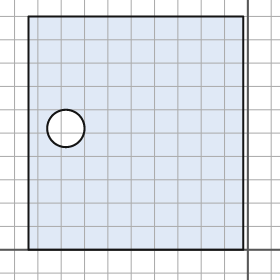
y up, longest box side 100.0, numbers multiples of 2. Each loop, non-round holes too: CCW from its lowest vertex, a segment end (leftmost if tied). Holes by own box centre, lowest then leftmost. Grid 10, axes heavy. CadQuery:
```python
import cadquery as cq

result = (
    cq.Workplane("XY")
    .moveTo(-94.0, 0.0)
    .lineTo(-2.0, 0.0)
    .lineTo(-2.0, 100.0)
    .lineTo(-94.0, 100.0)
    .close()
    .moveTo(-78.0, 52.0)
    .circle(8.0)
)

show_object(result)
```